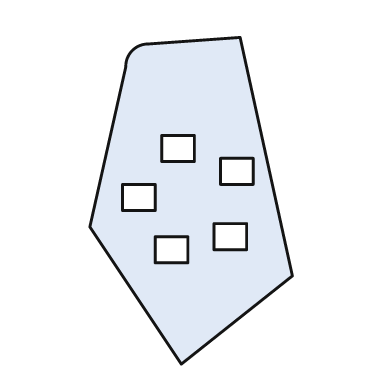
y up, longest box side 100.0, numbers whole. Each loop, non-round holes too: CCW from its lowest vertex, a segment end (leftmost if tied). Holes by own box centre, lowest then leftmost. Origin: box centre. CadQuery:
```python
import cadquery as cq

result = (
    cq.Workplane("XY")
    .moveTo(-3.0, -50.0)
    .lineTo(31.0, -23.0)
    .lineTo(15.0, 50.0)
    .lineTo(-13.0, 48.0)
    .threePointArc((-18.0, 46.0), (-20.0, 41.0))
    .lineTo(-31.0, -8.0)
    .close()
    .moveTo(-11.0, -19.0)
    .lineTo(-1.0, -19.0)
    .lineTo(-1.0, -11.0)
    .lineTo(-11.0, -11.0)
    .close()
    .moveTo(7.0, -15.0)
    .lineTo(17.0, -15.0)
    .lineTo(17.0, -7.0)
    .lineTo(7.0, -7.0)
    .close()
    .moveTo(-21.0, -3.0)
    .lineTo(-11.0, -3.0)
    .lineTo(-11.0, 5.0)
    .lineTo(-21.0, 5.0)
    .close()
    .moveTo(9.0, 5.0)
    .lineTo(19.0, 5.0)
    .lineTo(19.0, 13.0)
    .lineTo(9.0, 13.0)
    .close()
    .moveTo(-9.0, 12.0)
    .lineTo(1.0, 12.0)
    .lineTo(1.0, 20.0)
    .lineTo(-9.0, 20.0)
    .close()
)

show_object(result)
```